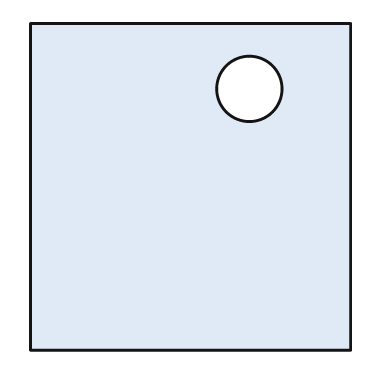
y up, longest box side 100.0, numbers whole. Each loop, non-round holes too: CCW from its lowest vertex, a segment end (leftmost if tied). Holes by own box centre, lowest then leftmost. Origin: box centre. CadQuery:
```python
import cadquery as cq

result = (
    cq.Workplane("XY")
    .moveTo(-49.0, -50.0)
    .lineTo(49.0, -50.0)
    .lineTo(49.0, 50.0)
    .lineTo(-49.0, 50.0)
    .close()
    .moveTo(18.0, 30.0)
    .circle(10.0)
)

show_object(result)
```